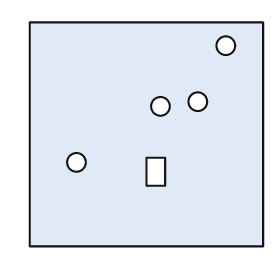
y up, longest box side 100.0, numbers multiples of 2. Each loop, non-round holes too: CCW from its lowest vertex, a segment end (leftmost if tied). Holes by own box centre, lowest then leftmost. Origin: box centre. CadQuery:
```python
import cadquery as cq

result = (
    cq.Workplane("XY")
    .moveTo(-50.0, -48.0)
    .lineTo(50.0, -48.0)
    .lineTo(50.0, 48.0)
    .lineTo(-50.0, 48.0)
    .close()
    .moveTo(0.0, -22.0)
    .lineTo(8.0, -22.0)
    .lineTo(8.0, -10.0)
    .lineTo(0.0, -10.0)
    .close()
    .moveTo(-30.0, -12.0)
    .circle(4.0)
    .moveTo(6.0, 12.0)
    .circle(4.0)
    .moveTo(22.0, 14.0)
    .circle(4.0)
    .moveTo(34.0, 38.0)
    .circle(4.0)
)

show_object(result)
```